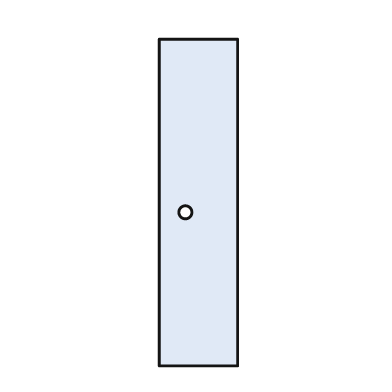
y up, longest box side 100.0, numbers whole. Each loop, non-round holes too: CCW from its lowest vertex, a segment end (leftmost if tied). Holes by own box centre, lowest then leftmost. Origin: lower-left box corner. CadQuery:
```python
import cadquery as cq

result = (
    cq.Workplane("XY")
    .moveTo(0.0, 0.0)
    .lineTo(24.0, 0.0)
    .lineTo(24.0, 100.0)
    .lineTo(0.0, 100.0)
    .close()
    .moveTo(8.0, 47.0)
    .circle(2.0)
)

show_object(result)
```